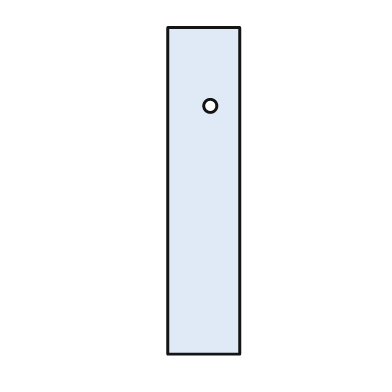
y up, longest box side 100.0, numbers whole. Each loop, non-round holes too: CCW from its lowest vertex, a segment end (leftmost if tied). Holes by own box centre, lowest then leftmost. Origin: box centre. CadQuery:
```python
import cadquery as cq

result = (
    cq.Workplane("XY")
    .moveTo(-11.0, -50.0)
    .lineTo(11.0, -50.0)
    .lineTo(11.0, 50.0)
    .lineTo(-11.0, 50.0)
    .close()
    .moveTo(2.0, 26.0)
    .circle(2.0)
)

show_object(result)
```